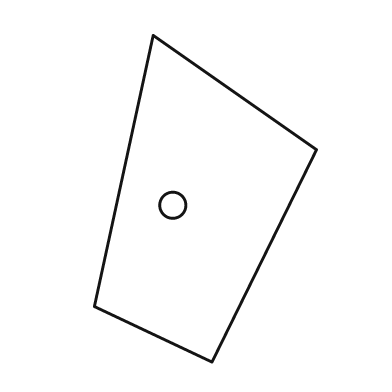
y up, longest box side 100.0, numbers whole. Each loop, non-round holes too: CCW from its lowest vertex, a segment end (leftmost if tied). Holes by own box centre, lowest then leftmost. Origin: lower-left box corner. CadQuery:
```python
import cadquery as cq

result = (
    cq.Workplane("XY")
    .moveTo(36.0, 0.0)
    .lineTo(68.0, 65.0)
    .lineTo(18.0, 100.0)
    .lineTo(0.0, 17.0)
    .close()
    .moveTo(24.0, 48.0)
    .circle(4.0)
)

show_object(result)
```